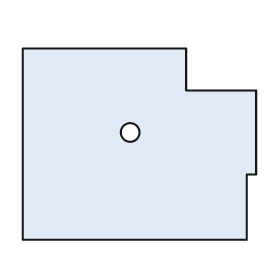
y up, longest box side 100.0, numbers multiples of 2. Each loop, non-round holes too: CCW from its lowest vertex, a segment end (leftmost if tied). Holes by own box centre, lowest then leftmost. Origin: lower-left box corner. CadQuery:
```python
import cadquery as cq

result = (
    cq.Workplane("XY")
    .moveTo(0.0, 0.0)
    .lineTo(96.0, 0.0)
    .lineTo(96.0, 28.0)
    .lineTo(100.0, 28.0)
    .lineTo(100.0, 64.0)
    .lineTo(70.0, 64.0)
    .lineTo(70.0, 82.0)
    .lineTo(0.0, 82.0)
    .close()
    .moveTo(46.0, 46.0)
    .circle(4.0)
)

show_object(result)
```